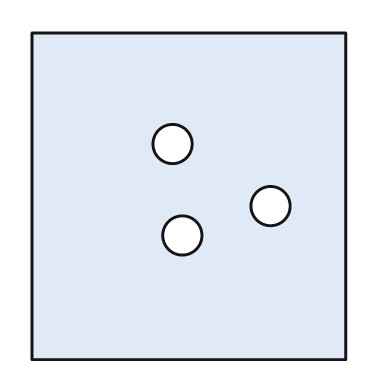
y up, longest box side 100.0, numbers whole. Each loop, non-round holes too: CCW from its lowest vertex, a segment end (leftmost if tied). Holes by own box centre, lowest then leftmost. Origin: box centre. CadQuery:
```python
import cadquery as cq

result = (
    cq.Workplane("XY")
    .moveTo(-48.0, -50.0)
    .lineTo(48.0, -50.0)
    .lineTo(48.0, 50.0)
    .lineTo(-48.0, 50.0)
    .close()
    .moveTo(-2.0, -12.0)
    .circle(6.0)
    .moveTo(25.0, -3.0)
    .circle(6.0)
    .moveTo(-5.0, 16.0)
    .circle(6.0)
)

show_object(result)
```